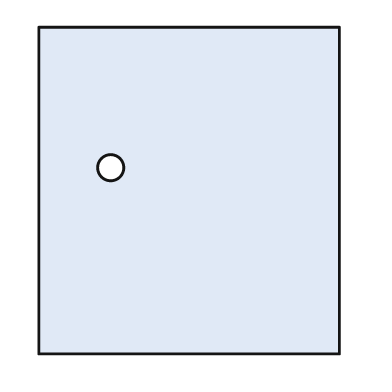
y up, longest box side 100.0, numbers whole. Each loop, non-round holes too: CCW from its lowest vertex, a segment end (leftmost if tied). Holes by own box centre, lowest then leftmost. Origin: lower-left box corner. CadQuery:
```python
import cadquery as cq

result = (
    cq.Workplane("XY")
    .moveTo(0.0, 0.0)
    .lineTo(92.0, 0.0)
    .lineTo(92.0, 100.0)
    .lineTo(0.0, 100.0)
    .close()
    .moveTo(22.0, 57.0)
    .circle(4.0)
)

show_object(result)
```